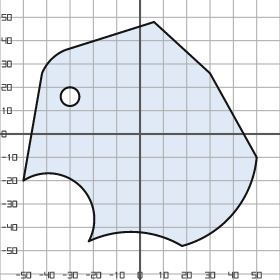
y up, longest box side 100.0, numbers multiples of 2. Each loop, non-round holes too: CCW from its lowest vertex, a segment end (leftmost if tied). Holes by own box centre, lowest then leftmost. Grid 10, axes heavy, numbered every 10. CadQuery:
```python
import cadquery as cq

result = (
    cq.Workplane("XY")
    .moveTo(18.0, -48.0)
    .threePointArc((40.0, -34.0), (50.0, -10.0))
    .lineTo(30.0, 26.0)
    .lineTo(6.0, 48.0)
    .lineTo(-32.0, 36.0)
    .threePointArc((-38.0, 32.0), (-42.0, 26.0))
    .lineTo(-50.0, -20.0)
    .threePointArc((-26.0, -22.0), (-22.0, -46.0))
    .threePointArc((-2.0, -42.0), (18.0, -48.0))
    .close()
    .moveTo(-30.0, 16.0)
    .circle(4.0)
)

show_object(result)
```